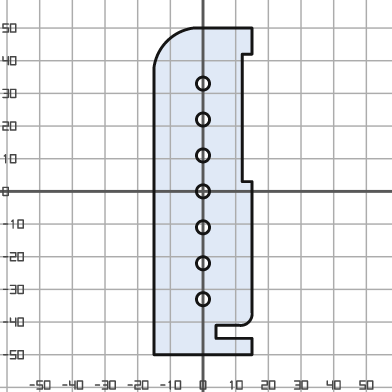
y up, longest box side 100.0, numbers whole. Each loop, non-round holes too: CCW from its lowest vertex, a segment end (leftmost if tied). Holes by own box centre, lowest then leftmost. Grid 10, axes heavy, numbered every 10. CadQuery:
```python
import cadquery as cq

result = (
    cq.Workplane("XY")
    .moveTo(-15.0, -50.0)
    .lineTo(15.0, -50.0)
    .lineTo(15.0, -45.0)
    .lineTo(4.0, -45.0)
    .lineTo(4.0, -41.0)
    .lineTo(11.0, -41.0)
    .threePointArc((14.0, -40.0), (15.0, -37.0))
    .lineTo(15.0, 3.0)
    .lineTo(12.0, 3.0)
    .lineTo(12.0, 42.0)
    .lineTo(15.0, 42.0)
    .lineTo(15.0, 50.0)
    .lineTo(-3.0, 50.0)
    .threePointArc((-11.0, 46.0), (-15.0, 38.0))
    .close()
    .moveTo(0.0, -33.0)
    .circle(2.0)
    .moveTo(0.0, -22.0)
    .circle(2.0)
    .moveTo(0.0, -11.0)
    .circle(2.0)
    .moveTo(0.0, 0.0)
    .circle(2.0)
    .moveTo(0.0, 11.0)
    .circle(2.0)
    .moveTo(0.0, 22.0)
    .circle(2.0)
    .moveTo(0.0, 33.0)
    .circle(2.0)
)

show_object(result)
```